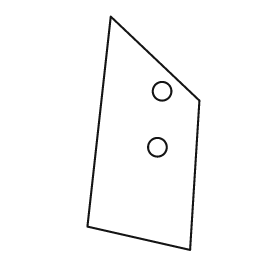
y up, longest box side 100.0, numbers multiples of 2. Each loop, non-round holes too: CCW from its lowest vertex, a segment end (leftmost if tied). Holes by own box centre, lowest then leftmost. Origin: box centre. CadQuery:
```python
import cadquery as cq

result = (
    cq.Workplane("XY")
    .moveTo(20.0, -50.0)
    .lineTo(24.0, 14.0)
    .lineTo(-14.0, 50.0)
    .lineTo(-24.0, -40.0)
    .close()
    .moveTo(6.0, -6.0)
    .circle(4.0)
    .moveTo(8.0, 18.0)
    .circle(4.0)
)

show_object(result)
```